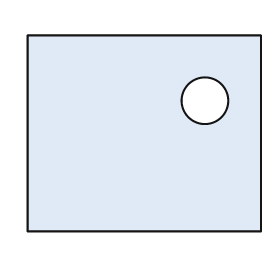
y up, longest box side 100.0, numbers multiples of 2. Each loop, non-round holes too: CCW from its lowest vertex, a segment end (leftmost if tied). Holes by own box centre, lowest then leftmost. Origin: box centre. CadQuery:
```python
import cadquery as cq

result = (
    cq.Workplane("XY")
    .moveTo(-50.0, -42.0)
    .lineTo(50.0, -42.0)
    .lineTo(50.0, 42.0)
    .lineTo(-50.0, 42.0)
    .close()
    .moveTo(26.0, 14.0)
    .circle(10.0)
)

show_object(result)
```